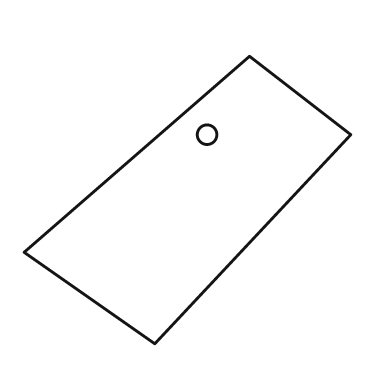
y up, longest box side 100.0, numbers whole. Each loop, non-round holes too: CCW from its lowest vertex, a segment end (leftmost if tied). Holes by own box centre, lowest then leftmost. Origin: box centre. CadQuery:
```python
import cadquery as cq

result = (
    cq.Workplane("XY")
    .moveTo(-10.0, -44.0)
    .lineTo(50.0, 20.0)
    .lineTo(19.0, 44.0)
    .lineTo(-50.0, -16.0)
    .close()
    .moveTo(6.0, 20.0)
    .circle(3.0)
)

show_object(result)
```